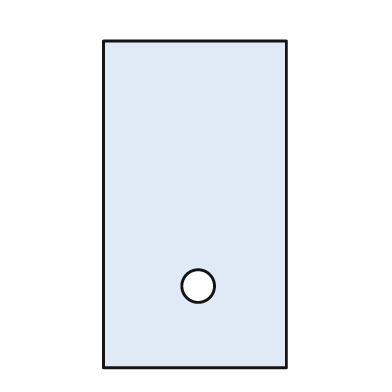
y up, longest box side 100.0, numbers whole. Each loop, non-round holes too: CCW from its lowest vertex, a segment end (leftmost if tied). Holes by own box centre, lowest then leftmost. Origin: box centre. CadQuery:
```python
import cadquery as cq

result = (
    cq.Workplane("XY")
    .moveTo(-28.0, -50.0)
    .lineTo(28.0, -50.0)
    .lineTo(28.0, 50.0)
    .lineTo(-28.0, 50.0)
    .close()
    .moveTo(1.0, -25.0)
    .circle(5.0)
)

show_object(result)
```